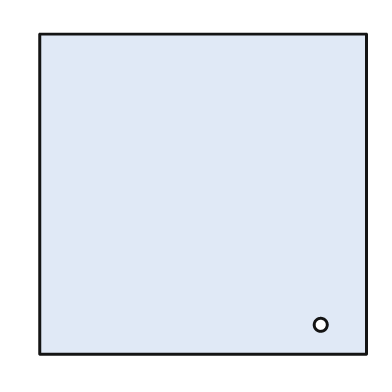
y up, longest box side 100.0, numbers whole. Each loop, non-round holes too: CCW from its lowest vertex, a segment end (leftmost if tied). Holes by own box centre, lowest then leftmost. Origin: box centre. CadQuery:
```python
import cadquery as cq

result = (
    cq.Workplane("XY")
    .moveTo(-50.0, -49.0)
    .lineTo(50.0, -49.0)
    .lineTo(50.0, 49.0)
    .lineTo(-50.0, 49.0)
    .close()
    .moveTo(36.0, -40.0)
    .circle(2.0)
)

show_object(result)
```